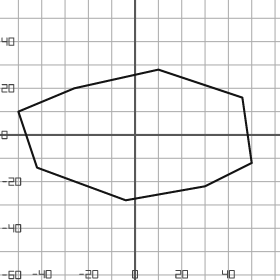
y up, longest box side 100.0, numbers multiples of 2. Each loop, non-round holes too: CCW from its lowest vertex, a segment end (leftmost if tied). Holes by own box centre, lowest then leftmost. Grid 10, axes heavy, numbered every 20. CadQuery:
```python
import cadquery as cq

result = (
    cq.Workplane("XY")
    .moveTo(-4.0, -28.0)
    .lineTo(30.0, -22.0)
    .lineTo(50.0, -12.0)
    .lineTo(46.0, 16.0)
    .lineTo(10.0, 28.0)
    .lineTo(-26.0, 20.0)
    .lineTo(-50.0, 10.0)
    .lineTo(-42.0, -14.0)
    .close()
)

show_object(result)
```